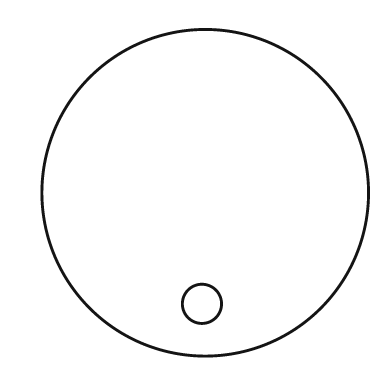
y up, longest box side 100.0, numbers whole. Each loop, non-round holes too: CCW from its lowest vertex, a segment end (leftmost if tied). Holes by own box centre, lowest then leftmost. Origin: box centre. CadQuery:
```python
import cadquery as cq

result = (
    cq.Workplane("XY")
    .moveTo(0.0, 0.0)
    .circle(50.0)
    .moveTo(-1.0, -34.0)
    .circle(6.0)
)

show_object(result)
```